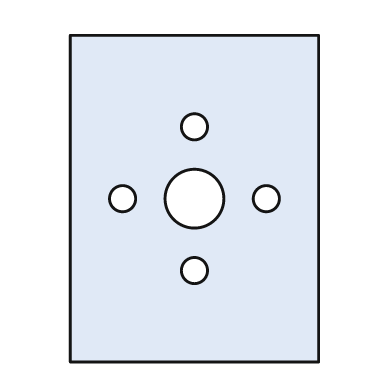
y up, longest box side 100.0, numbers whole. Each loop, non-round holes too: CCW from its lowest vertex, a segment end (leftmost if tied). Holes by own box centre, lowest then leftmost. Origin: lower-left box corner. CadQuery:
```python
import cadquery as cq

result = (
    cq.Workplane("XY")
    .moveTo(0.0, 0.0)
    .lineTo(76.0, 0.0)
    .lineTo(76.0, 100.0)
    .lineTo(0.0, 100.0)
    .close()
    .moveTo(38.0, 28.0)
    .circle(4.0)
    .moveTo(16.0, 50.0)
    .circle(4.0)
    .moveTo(38.0, 50.0)
    .circle(9.0)
    .moveTo(60.0, 50.0)
    .circle(4.0)
    .moveTo(38.0, 72.0)
    .circle(4.0)
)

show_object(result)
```